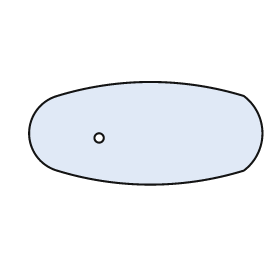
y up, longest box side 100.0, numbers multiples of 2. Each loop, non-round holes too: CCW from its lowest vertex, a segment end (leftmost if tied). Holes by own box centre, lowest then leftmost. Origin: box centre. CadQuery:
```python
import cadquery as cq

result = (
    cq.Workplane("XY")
    .moveTo(-38.0, -16.0)
    .threePointArc((2.0, -22.0), (42.0, -16.0))
    .threePointArc((50.0, 0.0), (42.0, 16.0))
    .threePointArc((2.0, 22.0), (-38.0, 16.0))
    .threePointArc((-50.0, 0.0), (-38.0, -16.0))
    .close()
    .moveTo(-20.0, -2.0)
    .circle(2.0)
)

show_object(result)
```